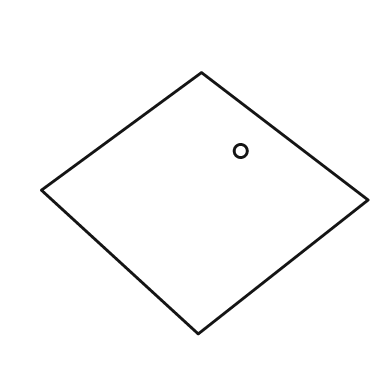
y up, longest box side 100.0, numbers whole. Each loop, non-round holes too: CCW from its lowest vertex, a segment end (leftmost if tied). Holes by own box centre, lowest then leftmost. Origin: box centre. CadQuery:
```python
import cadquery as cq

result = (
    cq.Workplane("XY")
    .moveTo(-2.0, -40.0)
    .lineTo(50.0, 1.0)
    .lineTo(-1.0, 40.0)
    .lineTo(-50.0, 4.0)
    .close()
    .moveTo(11.0, 16.0)
    .circle(2.0)
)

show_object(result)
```